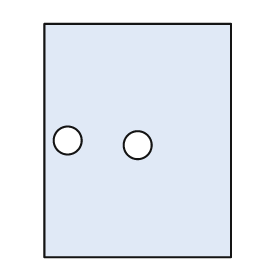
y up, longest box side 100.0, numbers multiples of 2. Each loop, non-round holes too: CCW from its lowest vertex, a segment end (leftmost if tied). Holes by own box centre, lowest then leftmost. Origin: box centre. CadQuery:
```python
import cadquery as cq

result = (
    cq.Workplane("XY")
    .moveTo(-40.0, -50.0)
    .lineTo(40.0, -50.0)
    .lineTo(40.0, 50.0)
    .lineTo(-40.0, 50.0)
    .close()
    .moveTo(0.0, -2.0)
    .circle(6.0)
    .moveTo(-30.0, 0.0)
    .circle(6.0)
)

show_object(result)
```